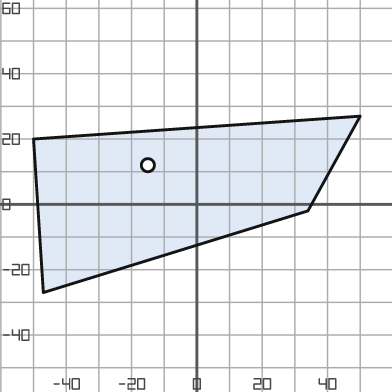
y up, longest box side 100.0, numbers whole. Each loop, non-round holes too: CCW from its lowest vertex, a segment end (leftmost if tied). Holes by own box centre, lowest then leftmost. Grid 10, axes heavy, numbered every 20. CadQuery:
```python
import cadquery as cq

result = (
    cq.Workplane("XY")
    .moveTo(-47.0, -27.0)
    .lineTo(34.0, -2.0)
    .lineTo(50.0, 27.0)
    .lineTo(-50.0, 20.0)
    .close()
    .moveTo(-15.0, 12.0)
    .circle(2.0)
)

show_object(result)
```